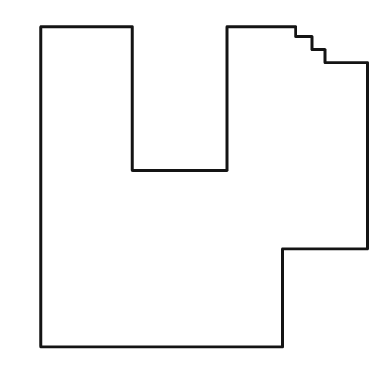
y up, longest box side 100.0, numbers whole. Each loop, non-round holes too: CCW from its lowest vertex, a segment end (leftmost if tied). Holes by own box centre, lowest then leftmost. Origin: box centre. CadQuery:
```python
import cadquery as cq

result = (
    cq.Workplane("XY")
    .moveTo(-50.0, -49.0)
    .lineTo(24.0, -49.0)
    .lineTo(24.0, -19.0)
    .lineTo(50.0, -19.0)
    .lineTo(50.0, 38.0)
    .lineTo(37.0, 38.0)
    .lineTo(37.0, 42.0)
    .lineTo(33.0, 42.0)
    .lineTo(33.0, 46.0)
    .lineTo(28.0, 46.0)
    .lineTo(28.0, 49.0)
    .lineTo(7.0, 49.0)
    .lineTo(7.0, 5.0)
    .lineTo(-22.0, 5.0)
    .lineTo(-22.0, 49.0)
    .lineTo(-50.0, 49.0)
    .close()
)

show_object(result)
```